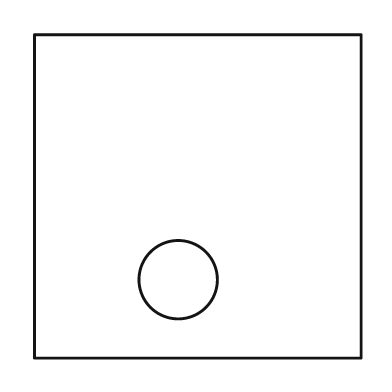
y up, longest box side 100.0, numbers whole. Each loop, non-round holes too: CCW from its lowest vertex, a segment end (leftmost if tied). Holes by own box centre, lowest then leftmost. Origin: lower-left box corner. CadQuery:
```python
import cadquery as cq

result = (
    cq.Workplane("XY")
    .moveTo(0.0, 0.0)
    .lineTo(100.0, 0.0)
    .lineTo(100.0, 99.0)
    .lineTo(0.0, 99.0)
    .close()
    .moveTo(44.0, 24.0)
    .circle(12.0)
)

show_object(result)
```